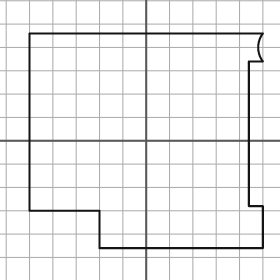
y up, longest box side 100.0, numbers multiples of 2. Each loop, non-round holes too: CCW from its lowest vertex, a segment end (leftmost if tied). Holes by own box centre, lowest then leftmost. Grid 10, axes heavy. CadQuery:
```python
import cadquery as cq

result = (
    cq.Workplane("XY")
    .moveTo(-20.0, -46.0)
    .lineTo(50.0, -46.0)
    .lineTo(50.0, -28.0)
    .lineTo(44.0, -28.0)
    .lineTo(44.0, 34.0)
    .lineTo(50.0, 34.0)
    .threePointArc((48.0, 40.0), (50.0, 46.0))
    .lineTo(-50.0, 46.0)
    .lineTo(-50.0, -30.0)
    .lineTo(-20.0, -30.0)
    .close()
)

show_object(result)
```